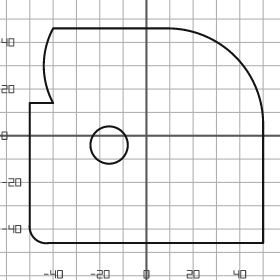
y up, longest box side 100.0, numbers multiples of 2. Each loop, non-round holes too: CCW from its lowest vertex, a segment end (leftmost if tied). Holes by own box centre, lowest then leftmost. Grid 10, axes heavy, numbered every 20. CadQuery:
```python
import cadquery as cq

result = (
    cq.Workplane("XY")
    .moveTo(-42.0, -46.0)
    .lineTo(50.0, -46.0)
    .lineTo(50.0, 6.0)
    .threePointArc((38.0, 34.0), (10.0, 46.0))
    .lineTo(-40.0, 46.0)
    .threePointArc((-44.0, 30.0), (-40.0, 14.0))
    .lineTo(-50.0, 14.0)
    .lineTo(-50.0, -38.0)
    .threePointArc((-48.0, -44.0), (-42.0, -46.0))
    .close()
    .moveTo(-16.0, -4.0)
    .circle(8.0)
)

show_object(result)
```